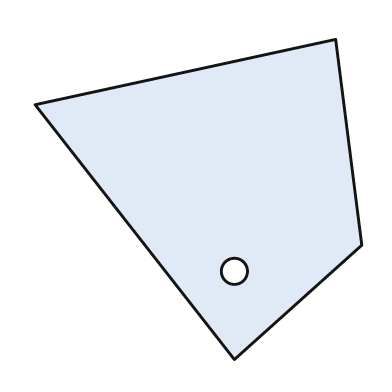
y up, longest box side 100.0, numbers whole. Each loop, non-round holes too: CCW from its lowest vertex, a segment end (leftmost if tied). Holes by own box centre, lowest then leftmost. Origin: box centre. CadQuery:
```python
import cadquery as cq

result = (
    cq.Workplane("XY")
    .moveTo(11.0, -49.0)
    .lineTo(50.0, -14.0)
    .lineTo(42.0, 49.0)
    .lineTo(-50.0, 29.0)
    .close()
    .moveTo(11.0, -22.0)
    .circle(4.0)
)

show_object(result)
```